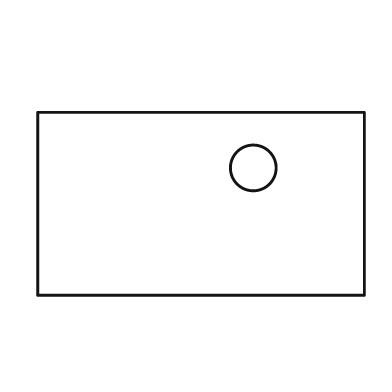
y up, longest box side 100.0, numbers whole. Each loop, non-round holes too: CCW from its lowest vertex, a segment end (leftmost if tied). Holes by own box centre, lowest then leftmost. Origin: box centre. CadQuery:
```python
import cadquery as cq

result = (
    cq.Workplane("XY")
    .moveTo(-50.0, -28.0)
    .lineTo(50.0, -28.0)
    .lineTo(50.0, 28.0)
    .lineTo(-50.0, 28.0)
    .close()
    .moveTo(16.0, 11.0)
    .circle(7.0)
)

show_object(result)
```